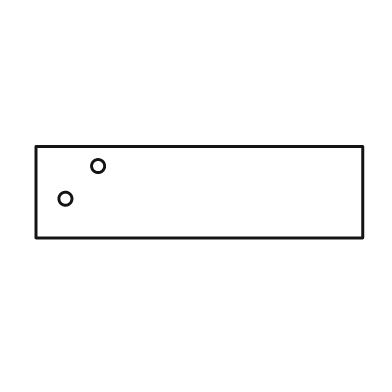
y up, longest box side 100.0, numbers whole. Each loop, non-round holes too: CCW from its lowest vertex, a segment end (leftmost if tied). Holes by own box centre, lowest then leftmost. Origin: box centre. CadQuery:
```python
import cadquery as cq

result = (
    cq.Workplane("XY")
    .moveTo(-50.0, -14.0)
    .lineTo(50.0, -14.0)
    .lineTo(50.0, 14.0)
    .lineTo(-50.0, 14.0)
    .close()
    .moveTo(-41.0, -2.0)
    .circle(2.0)
    .moveTo(-31.0, 8.0)
    .circle(2.0)
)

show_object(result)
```